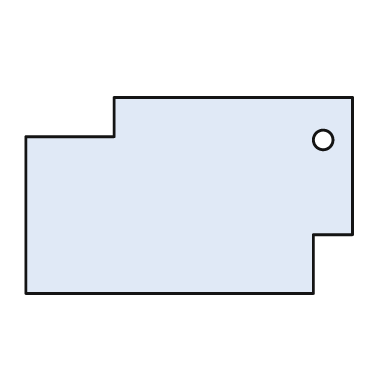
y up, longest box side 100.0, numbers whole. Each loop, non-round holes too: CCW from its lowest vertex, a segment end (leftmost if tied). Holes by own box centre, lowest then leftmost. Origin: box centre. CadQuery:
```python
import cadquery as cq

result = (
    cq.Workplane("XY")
    .moveTo(-50.0, -30.0)
    .lineTo(38.0, -30.0)
    .lineTo(38.0, -12.0)
    .lineTo(50.0, -12.0)
    .lineTo(50.0, 30.0)
    .lineTo(-23.0, 30.0)
    .lineTo(-23.0, 18.0)
    .lineTo(-50.0, 18.0)
    .close()
    .moveTo(41.0, 17.0)
    .circle(3.0)
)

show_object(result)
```